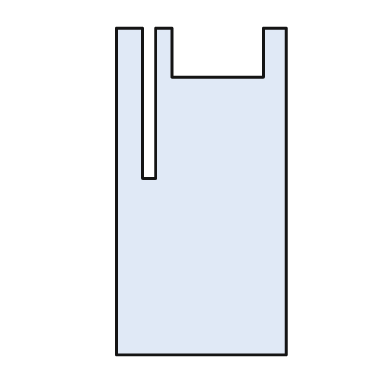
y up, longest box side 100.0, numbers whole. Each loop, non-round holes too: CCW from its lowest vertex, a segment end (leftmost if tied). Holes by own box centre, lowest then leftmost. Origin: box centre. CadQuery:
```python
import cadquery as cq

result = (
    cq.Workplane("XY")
    .moveTo(-26.0, -50.0)
    .lineTo(26.0, -50.0)
    .lineTo(26.0, 50.0)
    .lineTo(19.0, 50.0)
    .lineTo(19.0, 35.0)
    .lineTo(-9.0, 35.0)
    .lineTo(-9.0, 50.0)
    .lineTo(-14.0, 50.0)
    .lineTo(-14.0, 4.0)
    .lineTo(-18.0, 4.0)
    .lineTo(-18.0, 50.0)
    .lineTo(-26.0, 50.0)
    .close()
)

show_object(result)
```